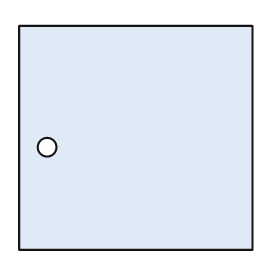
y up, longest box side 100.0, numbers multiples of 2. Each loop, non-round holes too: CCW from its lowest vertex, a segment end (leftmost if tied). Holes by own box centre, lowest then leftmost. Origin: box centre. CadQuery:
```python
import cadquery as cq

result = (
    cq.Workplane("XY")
    .moveTo(-50.0, -48.0)
    .lineTo(50.0, -48.0)
    .lineTo(50.0, 48.0)
    .lineTo(-50.0, 48.0)
    .close()
    .moveTo(-38.0, -4.0)
    .circle(4.0)
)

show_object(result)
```